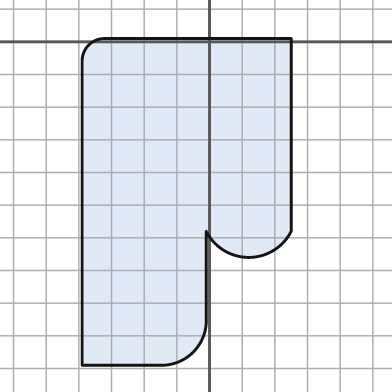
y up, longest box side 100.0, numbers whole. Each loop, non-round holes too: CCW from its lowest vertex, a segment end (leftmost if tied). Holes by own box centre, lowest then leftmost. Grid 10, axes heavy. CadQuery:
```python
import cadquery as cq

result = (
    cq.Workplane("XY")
    .moveTo(-39.0, -99.0)
    .lineTo(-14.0, -99.0)
    .threePointArc((-5.0, -95.0), (-1.0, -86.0))
    .lineTo(-1.0, -58.0)
    .threePointArc((12.0, -66.0), (25.0, -58.0))
    .lineTo(25.0, 1.0)
    .lineTo(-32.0, 1.0)
    .threePointArc((-37.0, -1.0), (-39.0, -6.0))
    .close()
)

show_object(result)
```